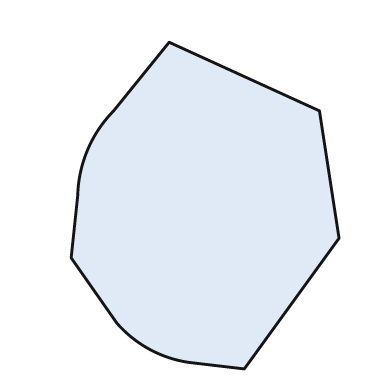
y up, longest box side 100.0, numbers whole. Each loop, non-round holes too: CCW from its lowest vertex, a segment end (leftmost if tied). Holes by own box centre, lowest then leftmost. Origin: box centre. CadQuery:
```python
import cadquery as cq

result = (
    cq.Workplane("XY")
    .moveTo(12.0, -50.0)
    .lineTo(41.0, -10.0)
    .lineTo(35.0, 29.0)
    .lineTo(-11.0, 50.0)
    .lineTo(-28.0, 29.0)
    .threePointArc((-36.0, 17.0), (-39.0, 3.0))
    .lineTo(-41.0, -16.0)
    .lineTo(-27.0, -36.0)
    .threePointArc((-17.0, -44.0), (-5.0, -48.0))
    .close()
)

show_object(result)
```